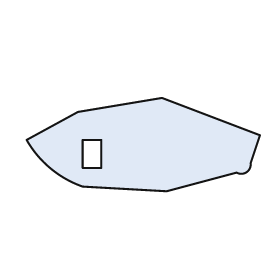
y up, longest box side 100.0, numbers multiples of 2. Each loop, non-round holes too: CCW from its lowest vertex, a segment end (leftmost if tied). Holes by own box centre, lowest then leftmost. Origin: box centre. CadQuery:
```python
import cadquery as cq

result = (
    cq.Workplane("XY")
    .moveTo(10.0, -20.0)
    .lineTo(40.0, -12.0)
    .threePointArc((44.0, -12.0), (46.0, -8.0))
    .lineTo(50.0, 4.0)
    .lineTo(8.0, 20.0)
    .lineTo(-28.0, 14.0)
    .lineTo(-50.0, 2.0)
    .threePointArc((-40.0, -10.0), (-26.0, -18.0))
    .close()
    .moveTo(-26.0, -10.0)
    .lineTo(-18.0, -10.0)
    .lineTo(-18.0, 2.0)
    .lineTo(-26.0, 2.0)
    .close()
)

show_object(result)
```